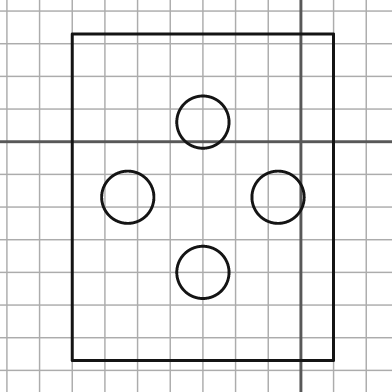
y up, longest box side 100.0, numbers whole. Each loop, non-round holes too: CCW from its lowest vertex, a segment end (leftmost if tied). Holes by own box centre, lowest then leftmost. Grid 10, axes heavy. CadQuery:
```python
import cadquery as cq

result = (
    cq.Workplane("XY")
    .moveTo(-70.0, -67.0)
    .lineTo(10.0, -67.0)
    .lineTo(10.0, 33.0)
    .lineTo(-70.0, 33.0)
    .close()
    .moveTo(-30.0, -40.0)
    .circle(8.0)
    .moveTo(-53.0, -17.0)
    .circle(8.0)
    .moveTo(-7.0, -17.0)
    .circle(8.0)
    .moveTo(-30.0, 6.0)
    .circle(8.0)
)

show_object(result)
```